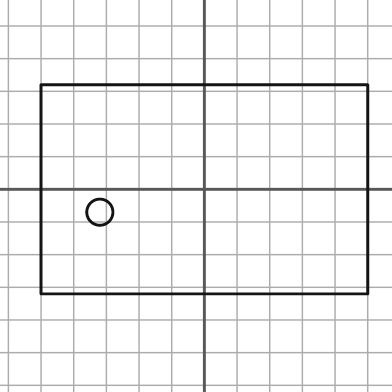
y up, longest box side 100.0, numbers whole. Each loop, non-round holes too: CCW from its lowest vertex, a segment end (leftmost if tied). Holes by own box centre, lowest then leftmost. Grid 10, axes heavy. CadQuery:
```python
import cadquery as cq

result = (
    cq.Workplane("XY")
    .moveTo(-50.0, -32.0)
    .lineTo(50.0, -32.0)
    .lineTo(50.0, 32.0)
    .lineTo(-50.0, 32.0)
    .close()
    .moveTo(-32.0, -7.0)
    .circle(4.0)
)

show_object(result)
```